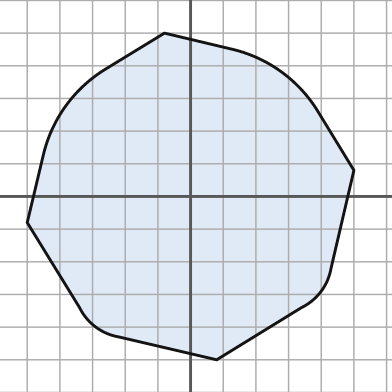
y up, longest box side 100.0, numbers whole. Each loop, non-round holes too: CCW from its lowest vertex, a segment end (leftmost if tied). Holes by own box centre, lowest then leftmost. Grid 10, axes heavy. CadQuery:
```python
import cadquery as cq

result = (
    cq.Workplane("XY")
    .moveTo(8.0, -50.0)
    .lineTo(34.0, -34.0)
    .threePointArc((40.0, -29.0), (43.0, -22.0))
    .lineTo(50.0, 8.0)
    .lineTo(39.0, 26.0)
    .threePointArc((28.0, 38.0), (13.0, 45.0))
    .lineTo(-8.0, 50.0)
    .lineTo(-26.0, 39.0)
    .threePointArc((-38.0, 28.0), (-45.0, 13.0))
    .lineTo(-50.0, -8.0)
    .lineTo(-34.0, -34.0)
    .threePointArc((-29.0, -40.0), (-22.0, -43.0))
    .close()
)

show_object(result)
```